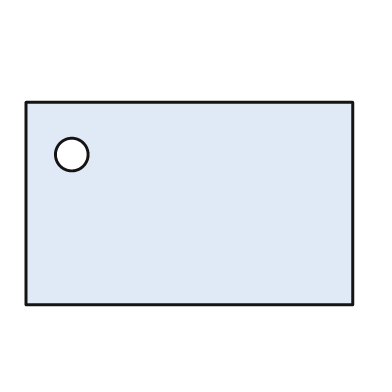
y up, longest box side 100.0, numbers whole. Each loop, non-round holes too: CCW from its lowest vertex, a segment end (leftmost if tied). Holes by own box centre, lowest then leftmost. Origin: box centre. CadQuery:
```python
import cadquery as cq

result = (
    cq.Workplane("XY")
    .moveTo(-50.0, -31.0)
    .lineTo(50.0, -31.0)
    .lineTo(50.0, 31.0)
    .lineTo(-50.0, 31.0)
    .close()
    .moveTo(-36.0, 15.0)
    .circle(5.0)
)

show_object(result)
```